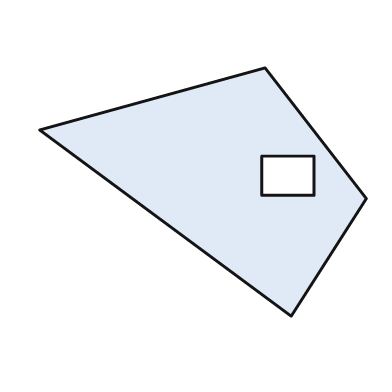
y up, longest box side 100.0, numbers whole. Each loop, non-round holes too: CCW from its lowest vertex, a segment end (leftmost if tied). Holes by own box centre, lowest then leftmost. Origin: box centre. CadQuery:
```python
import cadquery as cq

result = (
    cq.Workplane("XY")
    .moveTo(27.0, -38.0)
    .lineTo(50.0, -2.0)
    .lineTo(19.0, 38.0)
    .lineTo(-50.0, 19.0)
    .close()
    .moveTo(18.0, -1.0)
    .lineTo(34.0, -1.0)
    .lineTo(34.0, 11.0)
    .lineTo(18.0, 11.0)
    .close()
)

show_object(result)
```